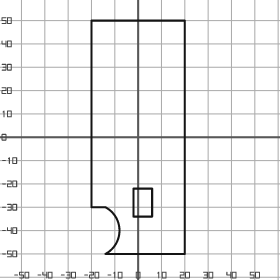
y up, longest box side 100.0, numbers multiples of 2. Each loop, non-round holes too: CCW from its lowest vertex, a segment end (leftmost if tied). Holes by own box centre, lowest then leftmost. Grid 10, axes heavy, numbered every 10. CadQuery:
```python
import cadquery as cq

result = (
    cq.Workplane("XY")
    .moveTo(-14.0, -50.0)
    .lineTo(20.0, -50.0)
    .lineTo(20.0, 50.0)
    .lineTo(-20.0, 50.0)
    .lineTo(-20.0, -30.0)
    .lineTo(-14.0, -30.0)
    .threePointArc((-8.0, -40.0), (-14.0, -50.0))
    .close()
    .moveTo(-2.0, -34.0)
    .lineTo(6.0, -34.0)
    .lineTo(6.0, -22.0)
    .lineTo(-2.0, -22.0)
    .close()
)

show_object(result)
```